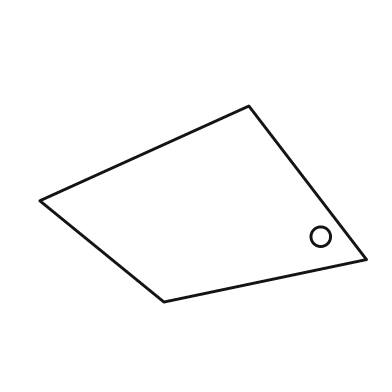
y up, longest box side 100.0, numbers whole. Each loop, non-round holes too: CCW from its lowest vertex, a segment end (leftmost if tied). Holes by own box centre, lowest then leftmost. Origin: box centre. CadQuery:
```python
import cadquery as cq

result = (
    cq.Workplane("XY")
    .moveTo(-12.0, -30.0)
    .lineTo(50.0, -17.0)
    .lineTo(14.0, 30.0)
    .lineTo(-50.0, 1.0)
    .close()
    .moveTo(36.0, -10.0)
    .circle(3.0)
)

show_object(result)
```